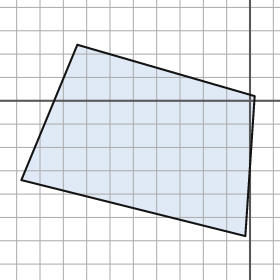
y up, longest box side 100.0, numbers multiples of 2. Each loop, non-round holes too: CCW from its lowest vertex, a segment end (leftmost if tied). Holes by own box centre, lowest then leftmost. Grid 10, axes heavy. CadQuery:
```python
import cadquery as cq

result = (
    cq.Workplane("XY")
    .moveTo(-2.0, -58.0)
    .lineTo(2.0, 2.0)
    .lineTo(-74.0, 24.0)
    .lineTo(-98.0, -34.0)
    .close()
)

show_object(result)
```